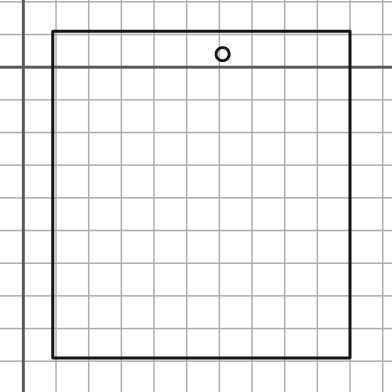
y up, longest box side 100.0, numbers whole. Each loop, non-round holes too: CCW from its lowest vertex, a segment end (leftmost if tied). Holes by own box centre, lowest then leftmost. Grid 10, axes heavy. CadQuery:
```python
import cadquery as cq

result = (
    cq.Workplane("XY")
    .moveTo(9.0, -89.0)
    .lineTo(100.0, -89.0)
    .lineTo(100.0, 11.0)
    .lineTo(9.0, 11.0)
    .close()
    .moveTo(61.0, 4.0)
    .circle(2.0)
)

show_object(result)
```